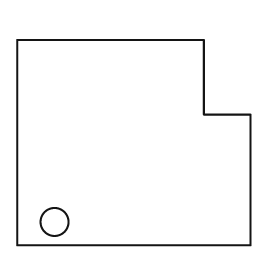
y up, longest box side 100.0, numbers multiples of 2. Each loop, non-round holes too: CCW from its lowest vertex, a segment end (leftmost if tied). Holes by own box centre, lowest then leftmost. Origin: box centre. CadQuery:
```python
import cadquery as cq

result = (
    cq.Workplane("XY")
    .moveTo(-50.0, -44.0)
    .lineTo(50.0, -44.0)
    .lineTo(50.0, 12.0)
    .lineTo(30.0, 12.0)
    .lineTo(30.0, 44.0)
    .lineTo(-50.0, 44.0)
    .close()
    .moveTo(-34.0, -34.0)
    .circle(6.0)
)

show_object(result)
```